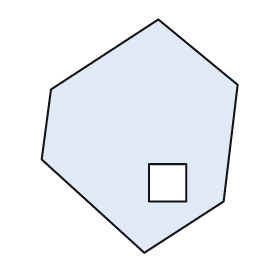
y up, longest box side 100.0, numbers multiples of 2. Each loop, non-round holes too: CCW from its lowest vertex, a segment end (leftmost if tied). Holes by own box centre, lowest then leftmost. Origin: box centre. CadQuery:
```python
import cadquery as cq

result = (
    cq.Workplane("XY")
    .moveTo(2.0, -50.0)
    .lineTo(36.0, -28.0)
    .lineTo(42.0, 22.0)
    .lineTo(8.0, 50.0)
    .lineTo(-38.0, 20.0)
    .lineTo(-42.0, -10.0)
    .close()
    .moveTo(4.0, -28.0)
    .lineTo(20.0, -28.0)
    .lineTo(20.0, -12.0)
    .lineTo(4.0, -12.0)
    .close()
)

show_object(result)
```